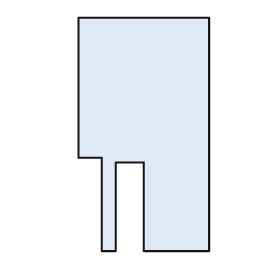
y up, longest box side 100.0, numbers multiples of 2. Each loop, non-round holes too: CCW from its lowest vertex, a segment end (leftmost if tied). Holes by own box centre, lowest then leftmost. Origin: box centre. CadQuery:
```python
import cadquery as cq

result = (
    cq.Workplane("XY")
    .moveTo(-18.0, -50.0)
    .lineTo(-12.0, -50.0)
    .lineTo(-12.0, -12.0)
    .lineTo(0.0, -12.0)
    .lineTo(0.0, -50.0)
    .lineTo(28.0, -50.0)
    .lineTo(28.0, 50.0)
    .lineTo(-28.0, 50.0)
    .lineTo(-28.0, -10.0)
    .lineTo(-18.0, -10.0)
    .close()
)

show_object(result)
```